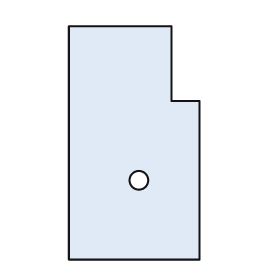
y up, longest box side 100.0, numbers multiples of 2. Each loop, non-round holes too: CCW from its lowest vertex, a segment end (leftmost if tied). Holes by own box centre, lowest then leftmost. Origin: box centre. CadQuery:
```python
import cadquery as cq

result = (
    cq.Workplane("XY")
    .moveTo(-28.0, -50.0)
    .lineTo(28.0, -50.0)
    .lineTo(28.0, 18.0)
    .lineTo(16.0, 18.0)
    .lineTo(16.0, 50.0)
    .lineTo(-28.0, 50.0)
    .close()
    .moveTo(2.0, -16.0)
    .circle(4.0)
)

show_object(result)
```